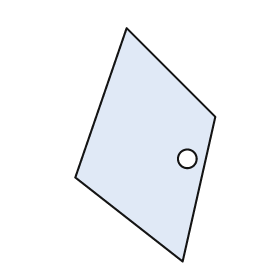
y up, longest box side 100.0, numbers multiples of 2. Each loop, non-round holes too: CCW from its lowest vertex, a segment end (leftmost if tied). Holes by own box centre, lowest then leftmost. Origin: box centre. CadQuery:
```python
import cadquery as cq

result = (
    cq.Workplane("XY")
    .moveTo(16.0, -50.0)
    .lineTo(30.0, 12.0)
    .lineTo(-8.0, 50.0)
    .lineTo(-30.0, -14.0)
    .close()
    .moveTo(18.0, -6.0)
    .circle(4.0)
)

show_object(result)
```